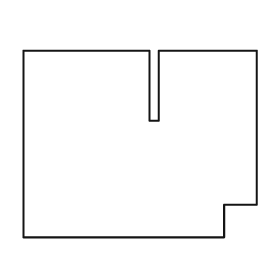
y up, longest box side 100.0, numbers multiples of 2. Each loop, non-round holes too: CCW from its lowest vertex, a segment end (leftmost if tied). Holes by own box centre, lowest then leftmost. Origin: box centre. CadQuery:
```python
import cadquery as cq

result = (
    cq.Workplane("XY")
    .moveTo(-50.0, -40.0)
    .lineTo(36.0, -40.0)
    .lineTo(36.0, -26.0)
    .lineTo(50.0, -26.0)
    .lineTo(50.0, 40.0)
    .lineTo(8.0, 40.0)
    .lineTo(8.0, 10.0)
    .lineTo(4.0, 10.0)
    .lineTo(4.0, 40.0)
    .lineTo(-50.0, 40.0)
    .close()
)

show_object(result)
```